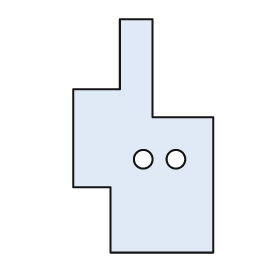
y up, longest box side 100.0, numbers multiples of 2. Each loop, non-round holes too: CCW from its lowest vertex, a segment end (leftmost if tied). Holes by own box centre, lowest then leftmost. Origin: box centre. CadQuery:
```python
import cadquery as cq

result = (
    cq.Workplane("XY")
    .moveTo(-14.0, -50.0)
    .lineTo(30.0, -50.0)
    .lineTo(30.0, 8.0)
    .lineTo(4.0, 8.0)
    .lineTo(4.0, 50.0)
    .lineTo(-10.0, 50.0)
    .lineTo(-10.0, 20.0)
    .lineTo(-30.0, 20.0)
    .lineTo(-30.0, -22.0)
    .lineTo(-14.0, -22.0)
    .close()
    .moveTo(0.0, -10.0)
    .circle(4.0)
    .moveTo(14.0, -10.0)
    .circle(4.0)
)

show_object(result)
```